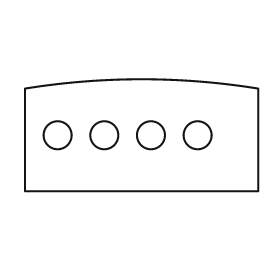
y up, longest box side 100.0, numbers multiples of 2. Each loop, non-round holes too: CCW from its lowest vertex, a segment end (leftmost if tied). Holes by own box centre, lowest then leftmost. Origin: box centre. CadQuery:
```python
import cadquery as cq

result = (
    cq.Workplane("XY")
    .moveTo(-50.0, -24.0)
    .lineTo(50.0, -24.0)
    .lineTo(50.0, 20.0)
    .threePointArc((0.0, 24.0), (-50.0, 20.0))
    .close()
    .moveTo(-36.0, 0.0)
    .circle(6.0)
    .moveTo(-16.0, 0.0)
    .circle(6.0)
    .moveTo(4.0, 0.0)
    .circle(6.0)
    .moveTo(24.0, 0.0)
    .circle(6.0)
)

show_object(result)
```